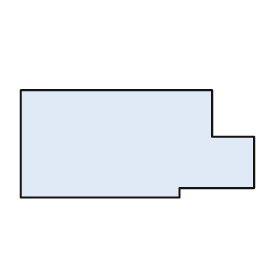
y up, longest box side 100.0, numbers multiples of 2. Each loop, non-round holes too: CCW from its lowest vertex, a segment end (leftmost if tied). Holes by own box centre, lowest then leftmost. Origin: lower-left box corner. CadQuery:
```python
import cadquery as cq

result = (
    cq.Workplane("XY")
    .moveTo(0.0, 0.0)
    .lineTo(68.0, 0.0)
    .lineTo(68.0, 4.0)
    .lineTo(100.0, 4.0)
    .lineTo(100.0, 26.0)
    .lineTo(82.0, 26.0)
    .lineTo(82.0, 46.0)
    .lineTo(0.0, 46.0)
    .close()
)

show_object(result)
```